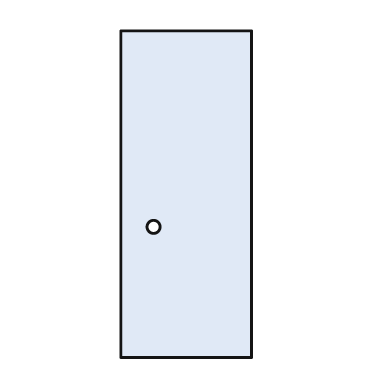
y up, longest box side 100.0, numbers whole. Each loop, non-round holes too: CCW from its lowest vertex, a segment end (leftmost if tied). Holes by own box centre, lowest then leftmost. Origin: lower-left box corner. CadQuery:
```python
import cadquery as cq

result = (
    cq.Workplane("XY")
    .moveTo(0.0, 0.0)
    .lineTo(40.0, 0.0)
    .lineTo(40.0, 100.0)
    .lineTo(0.0, 100.0)
    .close()
    .moveTo(10.0, 40.0)
    .circle(2.0)
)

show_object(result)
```